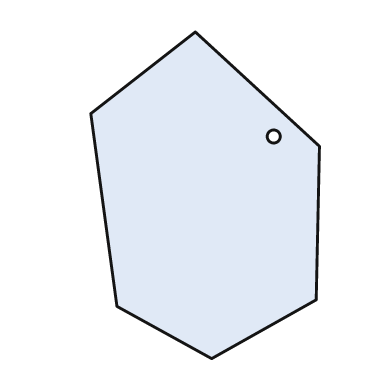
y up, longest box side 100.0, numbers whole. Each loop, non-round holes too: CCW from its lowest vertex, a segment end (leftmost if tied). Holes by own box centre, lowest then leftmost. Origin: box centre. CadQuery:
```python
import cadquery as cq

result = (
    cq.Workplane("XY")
    .moveTo(2.0, -50.0)
    .lineTo(34.0, -32.0)
    .lineTo(35.0, 15.0)
    .lineTo(-3.0, 50.0)
    .lineTo(-35.0, 25.0)
    .lineTo(-27.0, -34.0)
    .close()
    .moveTo(21.0, 18.0)
    .circle(2.0)
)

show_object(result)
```